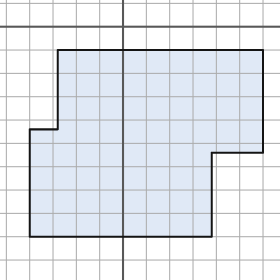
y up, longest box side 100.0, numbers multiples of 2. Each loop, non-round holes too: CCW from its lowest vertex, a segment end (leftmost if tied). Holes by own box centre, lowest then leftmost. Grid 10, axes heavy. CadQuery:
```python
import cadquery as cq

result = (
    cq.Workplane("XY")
    .moveTo(-40.0, -90.0)
    .lineTo(38.0, -90.0)
    .lineTo(38.0, -54.0)
    .lineTo(60.0, -54.0)
    .lineTo(60.0, -10.0)
    .lineTo(-28.0, -10.0)
    .lineTo(-28.0, -44.0)
    .lineTo(-40.0, -44.0)
    .close()
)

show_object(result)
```